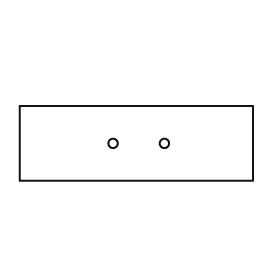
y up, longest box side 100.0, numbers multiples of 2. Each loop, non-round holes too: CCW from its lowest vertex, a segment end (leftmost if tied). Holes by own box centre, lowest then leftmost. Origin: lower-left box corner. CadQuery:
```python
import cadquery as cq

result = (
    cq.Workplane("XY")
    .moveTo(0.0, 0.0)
    .lineTo(100.0, 0.0)
    .lineTo(100.0, 32.0)
    .lineTo(0.0, 32.0)
    .close()
    .moveTo(40.0, 16.0)
    .circle(2.0)
    .moveTo(62.0, 16.0)
    .circle(2.0)
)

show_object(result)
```